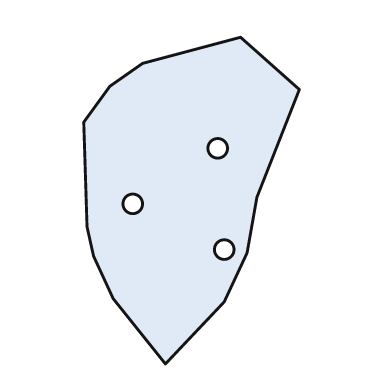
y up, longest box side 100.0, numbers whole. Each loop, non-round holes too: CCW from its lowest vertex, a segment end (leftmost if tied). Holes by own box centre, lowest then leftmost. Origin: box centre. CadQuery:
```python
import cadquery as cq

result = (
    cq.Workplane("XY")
    .moveTo(-8.0, -50.0)
    .lineTo(10.0, -31.0)
    .lineTo(17.0, -16.0)
    .lineTo(20.0, 1.0)
    .lineTo(33.0, 34.0)
    .lineTo(15.0, 50.0)
    .lineTo(-15.0, 42.0)
    .lineTo(-25.0, 35.0)
    .lineTo(-33.0, 24.0)
    .lineTo(-32.0, -8.0)
    .lineTo(-30.0, -17.0)
    .lineTo(-24.0, -30.0)
    .close()
    .moveTo(10.0, -15.0)
    .circle(3.0)
    .moveTo(-18.0, -1.0)
    .circle(3.0)
    .moveTo(8.0, 16.0)
    .circle(3.0)
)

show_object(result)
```